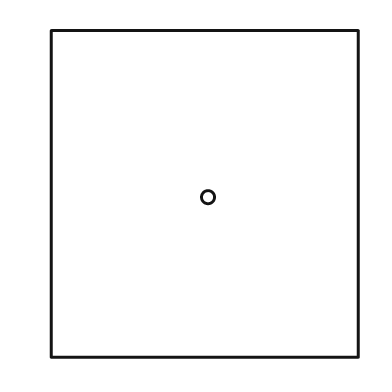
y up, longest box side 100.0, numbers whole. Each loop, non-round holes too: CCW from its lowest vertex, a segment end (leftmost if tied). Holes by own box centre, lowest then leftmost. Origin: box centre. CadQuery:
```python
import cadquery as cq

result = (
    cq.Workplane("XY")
    .moveTo(-47.0, -50.0)
    .lineTo(47.0, -50.0)
    .lineTo(47.0, 50.0)
    .lineTo(-47.0, 50.0)
    .close()
    .moveTo(1.0, -1.0)
    .circle(2.0)
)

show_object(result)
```